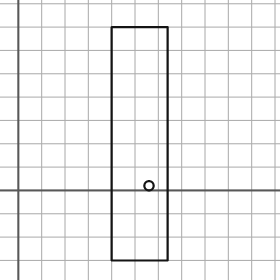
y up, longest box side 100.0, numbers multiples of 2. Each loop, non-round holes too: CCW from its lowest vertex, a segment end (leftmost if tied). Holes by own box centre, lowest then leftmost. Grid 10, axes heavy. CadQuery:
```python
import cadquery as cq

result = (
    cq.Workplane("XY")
    .moveTo(40.0, -30.0)
    .lineTo(64.0, -30.0)
    .lineTo(64.0, 70.0)
    .lineTo(40.0, 70.0)
    .close()
    .moveTo(56.0, 2.0)
    .circle(2.0)
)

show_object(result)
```